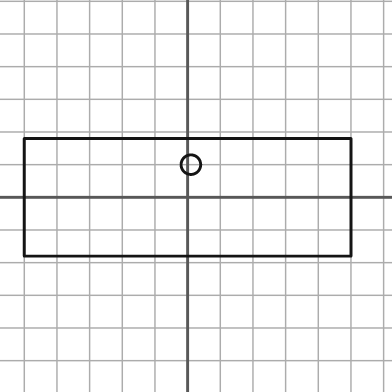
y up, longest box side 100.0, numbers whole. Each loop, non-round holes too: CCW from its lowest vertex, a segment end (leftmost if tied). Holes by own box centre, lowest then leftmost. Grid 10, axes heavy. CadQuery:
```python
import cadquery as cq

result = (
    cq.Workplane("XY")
    .moveTo(-50.0, -18.0)
    .lineTo(50.0, -18.0)
    .lineTo(50.0, 18.0)
    .lineTo(-50.0, 18.0)
    .close()
    .moveTo(1.0, 10.0)
    .circle(3.0)
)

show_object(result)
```